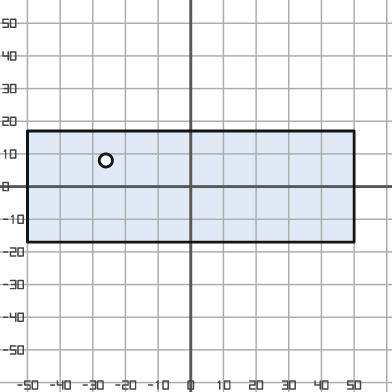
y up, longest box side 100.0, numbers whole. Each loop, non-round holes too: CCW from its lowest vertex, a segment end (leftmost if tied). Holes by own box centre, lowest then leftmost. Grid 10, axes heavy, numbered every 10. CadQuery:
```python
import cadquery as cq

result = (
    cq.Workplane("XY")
    .moveTo(-50.0, -17.0)
    .lineTo(50.0, -17.0)
    .lineTo(50.0, 17.0)
    .lineTo(-50.0, 17.0)
    .close()
    .moveTo(-26.0, 8.0)
    .circle(2.0)
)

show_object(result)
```